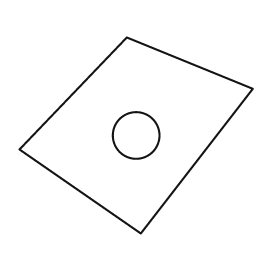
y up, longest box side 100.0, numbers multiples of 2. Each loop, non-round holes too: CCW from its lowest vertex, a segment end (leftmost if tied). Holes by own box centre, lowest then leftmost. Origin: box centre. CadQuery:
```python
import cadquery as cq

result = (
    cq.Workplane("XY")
    .moveTo(2.0, -42.0)
    .lineTo(50.0, 20.0)
    .lineTo(-4.0, 42.0)
    .lineTo(-50.0, -6.0)
    .close()
    .moveTo(0.0, 0.0)
    .circle(10.0)
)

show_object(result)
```